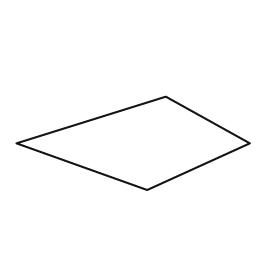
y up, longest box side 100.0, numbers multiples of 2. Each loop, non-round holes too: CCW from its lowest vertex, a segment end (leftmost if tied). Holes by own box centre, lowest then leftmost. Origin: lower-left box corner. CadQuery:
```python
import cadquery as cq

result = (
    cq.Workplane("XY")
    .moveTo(56.0, 0.0)
    .lineTo(100.0, 20.0)
    .lineTo(64.0, 40.0)
    .lineTo(0.0, 20.0)
    .close()
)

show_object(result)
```